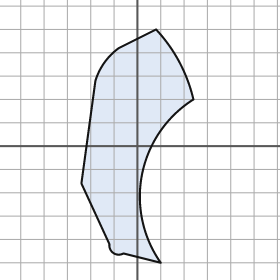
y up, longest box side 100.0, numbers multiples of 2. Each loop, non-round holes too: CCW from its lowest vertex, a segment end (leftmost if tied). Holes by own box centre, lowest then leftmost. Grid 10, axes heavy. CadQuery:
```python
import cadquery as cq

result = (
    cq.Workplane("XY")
    .moveTo(10.0, -50.0)
    .threePointArc((2.0, -12.0), (24.0, 20.0))
    .threePointArc((18.0, 36.0), (8.0, 50.0))
    .lineTo(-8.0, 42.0)
    .threePointArc((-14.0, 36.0), (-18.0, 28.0))
    .lineTo(-24.0, -16.0)
    .lineTo(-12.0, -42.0)
    .threePointArc((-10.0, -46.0), (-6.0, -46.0))
    .close()
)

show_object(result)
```